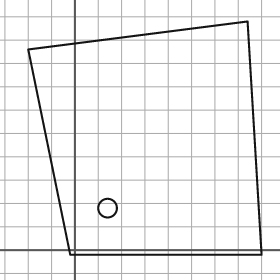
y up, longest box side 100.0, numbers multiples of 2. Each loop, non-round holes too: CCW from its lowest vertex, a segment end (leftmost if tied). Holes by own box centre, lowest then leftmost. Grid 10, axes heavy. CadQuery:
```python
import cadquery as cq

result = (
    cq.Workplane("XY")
    .moveTo(-2.0, -2.0)
    .lineTo(80.0, -2.0)
    .lineTo(74.0, 98.0)
    .lineTo(-20.0, 86.0)
    .close()
    .moveTo(14.0, 18.0)
    .circle(4.0)
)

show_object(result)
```